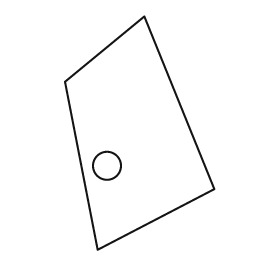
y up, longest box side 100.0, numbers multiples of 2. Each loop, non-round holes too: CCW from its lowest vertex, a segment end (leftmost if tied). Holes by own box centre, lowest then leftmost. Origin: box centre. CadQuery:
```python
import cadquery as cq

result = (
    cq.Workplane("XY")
    .moveTo(-18.0, -50.0)
    .lineTo(32.0, -24.0)
    .lineTo(2.0, 50.0)
    .lineTo(-32.0, 22.0)
    .close()
    .moveTo(-14.0, -14.0)
    .circle(6.0)
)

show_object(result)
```